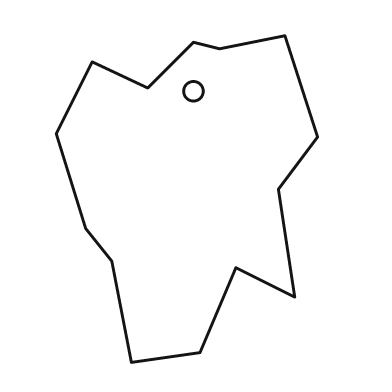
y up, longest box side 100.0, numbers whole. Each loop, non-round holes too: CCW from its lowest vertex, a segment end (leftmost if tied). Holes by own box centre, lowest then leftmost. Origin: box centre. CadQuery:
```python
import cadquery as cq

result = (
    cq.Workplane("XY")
    .moveTo(-17.0, -50.0)
    .lineTo(4.0, -47.0)
    .lineTo(15.0, -21.0)
    .lineTo(33.0, -30.0)
    .lineTo(28.0, 3.0)
    .lineTo(40.0, 19.0)
    .lineTo(30.0, 50.0)
    .lineTo(10.0, 46.0)
    .lineTo(2.0, 48.0)
    .lineTo(-12.0, 34.0)
    .lineTo(-29.0, 42.0)
    .lineTo(-40.0, 20.0)
    .lineTo(-31.0, -9.0)
    .lineTo(-23.0, -19.0)
    .close()
    .moveTo(2.0, 33.0)
    .circle(3.0)
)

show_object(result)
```